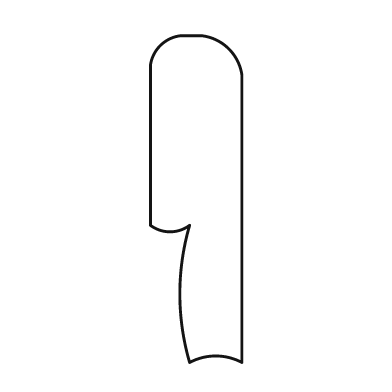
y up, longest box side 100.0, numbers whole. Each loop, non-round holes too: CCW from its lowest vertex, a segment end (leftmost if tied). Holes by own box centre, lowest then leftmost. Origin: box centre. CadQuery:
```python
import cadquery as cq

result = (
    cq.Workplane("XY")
    .moveTo(-2.0, -50.0)
    .threePointArc((6.0, -48.0), (14.0, -50.0))
    .lineTo(14.0, 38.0)
    .threePointArc((10.0, 46.0), (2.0, 50.0))
    .lineTo(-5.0, 50.0)
    .threePointArc((-11.0, 47.0), (-14.0, 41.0))
    .lineTo(-14.0, -8.0)
    .threePointArc((-8.0, -10.0), (-2.0, -8.0))
    .threePointArc((-5.0, -29.0), (-2.0, -50.0))
    .close()
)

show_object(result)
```